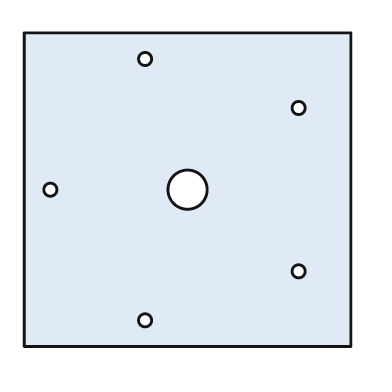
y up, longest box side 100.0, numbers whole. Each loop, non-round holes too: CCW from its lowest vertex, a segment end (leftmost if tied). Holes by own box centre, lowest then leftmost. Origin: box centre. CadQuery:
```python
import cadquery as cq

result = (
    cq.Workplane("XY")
    .moveTo(-50.0, -48.0)
    .lineTo(50.0, -48.0)
    .lineTo(50.0, 48.0)
    .lineTo(-50.0, 48.0)
    .close()
    .moveTo(-13.0, -40.0)
    .circle(2.0)
    .moveTo(34.0, -25.0)
    .circle(2.0)
    .moveTo(-42.0, 0.0)
    .circle(2.0)
    .moveTo(0.0, 0.0)
    .circle(6.0)
    .moveTo(34.0, 25.0)
    .circle(2.0)
    .moveTo(-13.0, 40.0)
    .circle(2.0)
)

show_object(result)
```